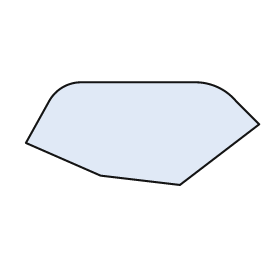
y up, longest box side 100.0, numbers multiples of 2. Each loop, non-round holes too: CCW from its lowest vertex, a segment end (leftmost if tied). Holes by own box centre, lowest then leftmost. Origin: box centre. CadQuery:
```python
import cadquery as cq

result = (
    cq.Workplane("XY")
    .moveTo(16.0, -22.0)
    .lineTo(50.0, 4.0)
    .lineTo(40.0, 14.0)
    .threePointArc((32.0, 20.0), (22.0, 22.0))
    .lineTo(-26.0, 22.0)
    .threePointArc((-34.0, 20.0), (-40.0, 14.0))
    .lineTo(-50.0, -4.0)
    .lineTo(-18.0, -18.0)
    .close()
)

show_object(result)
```